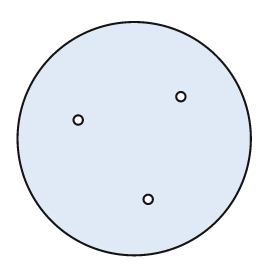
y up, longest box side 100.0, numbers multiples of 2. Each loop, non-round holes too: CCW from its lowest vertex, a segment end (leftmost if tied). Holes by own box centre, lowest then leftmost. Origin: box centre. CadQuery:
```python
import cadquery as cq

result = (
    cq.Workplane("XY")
    .moveTo(0.0, 0.0)
    .circle(50.0)
    .moveTo(6.0, -26.0)
    .circle(2.0)
    .moveTo(-24.0, 8.0)
    .circle(2.0)
    .moveTo(20.0, 18.0)
    .circle(2.0)
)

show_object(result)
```